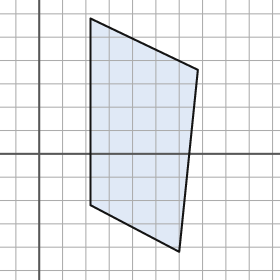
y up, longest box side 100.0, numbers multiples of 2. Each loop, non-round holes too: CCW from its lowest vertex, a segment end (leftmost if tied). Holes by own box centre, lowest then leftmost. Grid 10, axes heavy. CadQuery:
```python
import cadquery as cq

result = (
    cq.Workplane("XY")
    .moveTo(60.0, -42.0)
    .lineTo(68.0, 36.0)
    .lineTo(22.0, 58.0)
    .lineTo(22.0, -22.0)
    .close()
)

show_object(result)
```